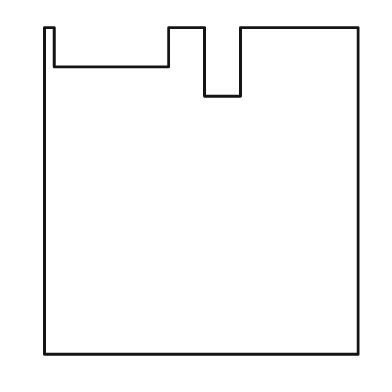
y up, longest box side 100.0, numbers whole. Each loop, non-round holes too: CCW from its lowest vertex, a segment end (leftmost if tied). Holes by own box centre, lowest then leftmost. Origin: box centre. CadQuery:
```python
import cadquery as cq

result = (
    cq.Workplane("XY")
    .moveTo(-48.0, -50.0)
    .lineTo(48.0, -50.0)
    .lineTo(48.0, 50.0)
    .lineTo(12.0, 50.0)
    .lineTo(12.0, 29.0)
    .lineTo(1.0, 29.0)
    .lineTo(1.0, 50.0)
    .lineTo(-10.0, 50.0)
    .lineTo(-10.0, 38.0)
    .lineTo(-45.0, 38.0)
    .lineTo(-45.0, 50.0)
    .lineTo(-48.0, 50.0)
    .close()
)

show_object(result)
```